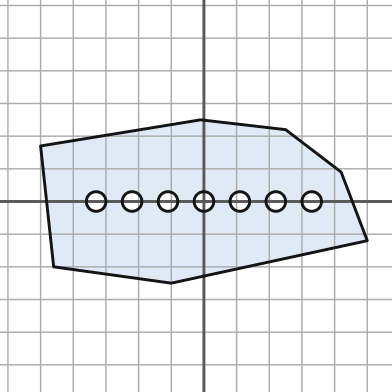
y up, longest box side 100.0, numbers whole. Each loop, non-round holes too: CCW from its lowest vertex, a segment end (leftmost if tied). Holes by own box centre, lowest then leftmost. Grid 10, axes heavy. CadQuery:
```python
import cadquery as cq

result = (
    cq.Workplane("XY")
    .moveTo(-10.0, -25.0)
    .lineTo(50.0, -12.0)
    .lineTo(42.0, 9.0)
    .lineTo(25.0, 22.0)
    .lineTo(-1.0, 25.0)
    .lineTo(-50.0, 17.0)
    .lineTo(-46.0, -20.0)
    .close()
    .moveTo(-33.0, 0.0)
    .circle(3.0)
    .moveTo(-22.0, 0.0)
    .circle(3.0)
    .moveTo(-11.0, 0.0)
    .circle(3.0)
    .moveTo(0.0, 0.0)
    .circle(3.0)
    .moveTo(11.0, 0.0)
    .circle(3.0)
    .moveTo(22.0, 0.0)
    .circle(3.0)
    .moveTo(33.0, 0.0)
    .circle(3.0)
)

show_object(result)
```